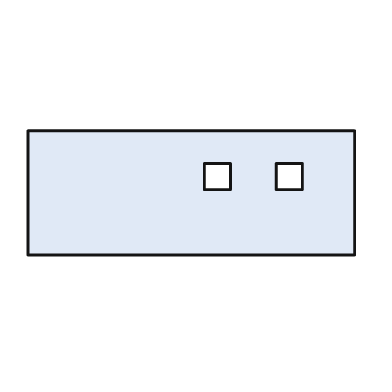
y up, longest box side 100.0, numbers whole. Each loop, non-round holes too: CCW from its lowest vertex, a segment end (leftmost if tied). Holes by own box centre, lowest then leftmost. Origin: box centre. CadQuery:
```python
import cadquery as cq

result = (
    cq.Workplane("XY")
    .moveTo(-50.0, -19.0)
    .lineTo(50.0, -19.0)
    .lineTo(50.0, 19.0)
    .lineTo(-50.0, 19.0)
    .close()
    .moveTo(4.0, 1.0)
    .lineTo(12.0, 1.0)
    .lineTo(12.0, 9.0)
    .lineTo(4.0, 9.0)
    .close()
    .moveTo(26.0, 1.0)
    .lineTo(34.0, 1.0)
    .lineTo(34.0, 9.0)
    .lineTo(26.0, 9.0)
    .close()
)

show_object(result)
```